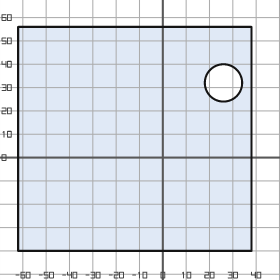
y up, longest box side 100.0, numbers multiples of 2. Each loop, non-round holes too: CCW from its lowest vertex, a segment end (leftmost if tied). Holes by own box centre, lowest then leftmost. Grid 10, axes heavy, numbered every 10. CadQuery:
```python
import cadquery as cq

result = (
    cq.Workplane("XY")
    .moveTo(-62.0, -40.0)
    .lineTo(38.0, -40.0)
    .lineTo(38.0, 56.0)
    .lineTo(-62.0, 56.0)
    .close()
    .moveTo(26.0, 32.0)
    .circle(8.0)
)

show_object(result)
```